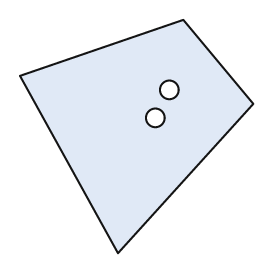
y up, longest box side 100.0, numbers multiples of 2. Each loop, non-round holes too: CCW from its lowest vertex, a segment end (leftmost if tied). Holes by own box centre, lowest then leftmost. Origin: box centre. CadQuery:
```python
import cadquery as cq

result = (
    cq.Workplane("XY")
    .moveTo(-8.0, -50.0)
    .lineTo(50.0, 14.0)
    .lineTo(20.0, 50.0)
    .lineTo(-50.0, 26.0)
    .close()
    .moveTo(8.0, 8.0)
    .circle(4.0)
    .moveTo(14.0, 20.0)
    .circle(4.0)
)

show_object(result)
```